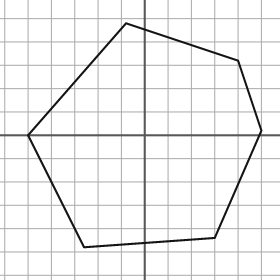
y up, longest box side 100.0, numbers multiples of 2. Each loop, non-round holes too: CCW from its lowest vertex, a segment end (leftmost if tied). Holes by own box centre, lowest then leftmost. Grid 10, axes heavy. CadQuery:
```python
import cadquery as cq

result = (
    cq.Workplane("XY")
    .moveTo(-26.0, -48.0)
    .lineTo(30.0, -44.0)
    .lineTo(50.0, 2.0)
    .lineTo(40.0, 32.0)
    .lineTo(-8.0, 48.0)
    .lineTo(-50.0, 0.0)
    .close()
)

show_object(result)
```